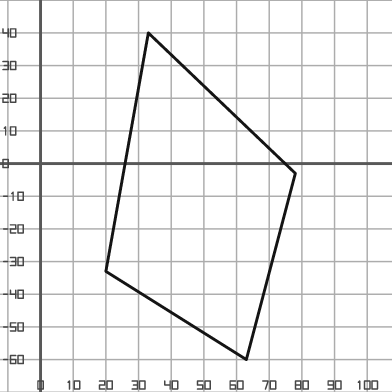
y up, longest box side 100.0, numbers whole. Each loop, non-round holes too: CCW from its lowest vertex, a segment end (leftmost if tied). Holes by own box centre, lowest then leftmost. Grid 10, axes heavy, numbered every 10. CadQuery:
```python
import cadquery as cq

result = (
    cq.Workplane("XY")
    .moveTo(63.0, -60.0)
    .lineTo(78.0, -3.0)
    .lineTo(33.0, 40.0)
    .lineTo(20.0, -33.0)
    .close()
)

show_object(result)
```